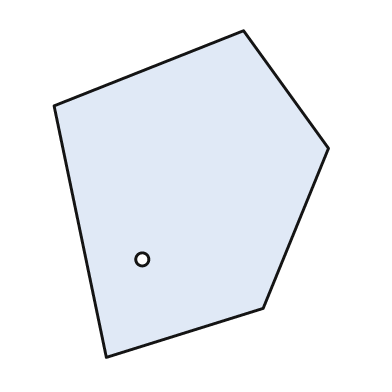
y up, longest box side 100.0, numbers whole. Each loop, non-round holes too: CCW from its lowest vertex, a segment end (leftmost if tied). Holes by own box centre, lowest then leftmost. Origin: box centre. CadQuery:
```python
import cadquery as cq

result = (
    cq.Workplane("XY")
    .moveTo(-26.0, -50.0)
    .lineTo(22.0, -35.0)
    .lineTo(42.0, 14.0)
    .lineTo(16.0, 50.0)
    .lineTo(-42.0, 27.0)
    .close()
    .moveTo(-15.0, -20.0)
    .circle(2.0)
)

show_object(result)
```